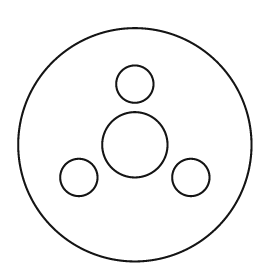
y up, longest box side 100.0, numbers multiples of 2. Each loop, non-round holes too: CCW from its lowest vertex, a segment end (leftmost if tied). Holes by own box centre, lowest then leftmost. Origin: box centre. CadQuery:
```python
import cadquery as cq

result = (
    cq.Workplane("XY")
    .moveTo(0.0, 0.0)
    .circle(50.0)
    .moveTo(-24.0, -14.0)
    .circle(8.0)
    .moveTo(24.0, -14.0)
    .circle(8.0)
    .moveTo(0.0, 0.0)
    .circle(14.0)
    .moveTo(0.0, 26.0)
    .circle(8.0)
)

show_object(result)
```